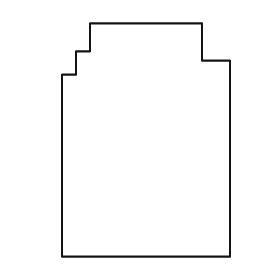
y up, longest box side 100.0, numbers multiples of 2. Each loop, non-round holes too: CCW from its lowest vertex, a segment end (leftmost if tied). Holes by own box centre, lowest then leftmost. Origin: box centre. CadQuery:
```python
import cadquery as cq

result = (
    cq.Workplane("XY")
    .moveTo(-36.0, -50.0)
    .lineTo(36.0, -50.0)
    .lineTo(36.0, 34.0)
    .lineTo(24.0, 34.0)
    .lineTo(24.0, 50.0)
    .lineTo(-24.0, 50.0)
    .lineTo(-24.0, 38.0)
    .lineTo(-30.0, 38.0)
    .lineTo(-30.0, 28.0)
    .lineTo(-36.0, 28.0)
    .close()
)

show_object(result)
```